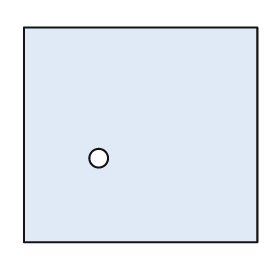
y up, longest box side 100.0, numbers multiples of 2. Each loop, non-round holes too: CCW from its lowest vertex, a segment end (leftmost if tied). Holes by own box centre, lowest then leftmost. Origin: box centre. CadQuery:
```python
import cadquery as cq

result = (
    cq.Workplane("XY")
    .moveTo(-50.0, -46.0)
    .lineTo(50.0, -46.0)
    .lineTo(50.0, 46.0)
    .lineTo(-50.0, 46.0)
    .close()
    .moveTo(-18.0, -10.0)
    .circle(4.0)
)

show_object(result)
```